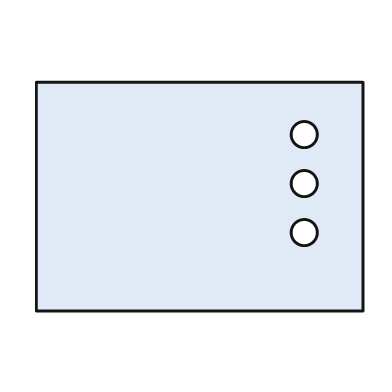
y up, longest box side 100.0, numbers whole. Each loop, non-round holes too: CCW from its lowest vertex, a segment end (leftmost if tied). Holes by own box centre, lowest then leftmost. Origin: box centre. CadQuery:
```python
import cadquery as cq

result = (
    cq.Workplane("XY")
    .moveTo(-50.0, -35.0)
    .lineTo(50.0, -35.0)
    .lineTo(50.0, 35.0)
    .lineTo(-50.0, 35.0)
    .close()
    .moveTo(32.0, -11.0)
    .circle(4.0)
    .moveTo(32.0, 4.0)
    .circle(4.0)
    .moveTo(32.0, 19.0)
    .circle(4.0)
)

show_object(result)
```